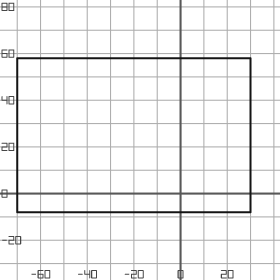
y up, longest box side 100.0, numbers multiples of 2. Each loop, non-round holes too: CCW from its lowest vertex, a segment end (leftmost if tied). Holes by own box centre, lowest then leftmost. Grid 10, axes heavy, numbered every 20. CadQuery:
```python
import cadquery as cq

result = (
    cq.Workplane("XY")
    .moveTo(-70.0, -8.0)
    .lineTo(30.0, -8.0)
    .lineTo(30.0, 58.0)
    .lineTo(-70.0, 58.0)
    .close()
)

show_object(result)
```